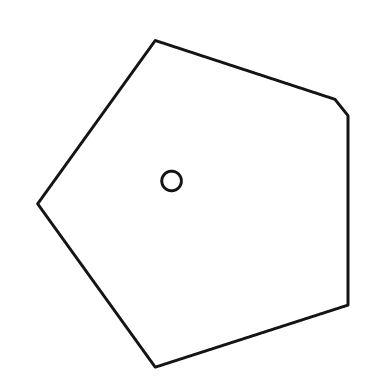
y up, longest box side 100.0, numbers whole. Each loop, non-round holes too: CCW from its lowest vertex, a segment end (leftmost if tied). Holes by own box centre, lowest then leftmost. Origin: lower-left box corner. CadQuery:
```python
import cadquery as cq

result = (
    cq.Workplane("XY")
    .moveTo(36.0, 0.0)
    .lineTo(95.0, 19.0)
    .lineTo(95.0, 77.0)
    .lineTo(91.0, 82.0)
    .lineTo(36.0, 100.0)
    .lineTo(0.0, 50.0)
    .close()
    .moveTo(41.0, 57.0)
    .circle(3.0)
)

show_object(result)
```